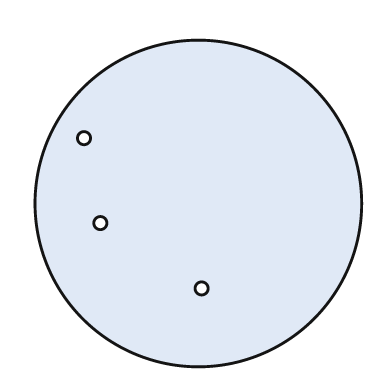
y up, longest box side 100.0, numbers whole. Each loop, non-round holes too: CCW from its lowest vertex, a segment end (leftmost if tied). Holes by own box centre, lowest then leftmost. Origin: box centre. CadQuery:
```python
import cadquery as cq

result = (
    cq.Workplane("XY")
    .moveTo(0.0, 0.0)
    .circle(50.0)
    .moveTo(1.0, -26.0)
    .circle(2.0)
    .moveTo(-30.0, -6.0)
    .circle(2.0)
    .moveTo(-35.0, 20.0)
    .circle(2.0)
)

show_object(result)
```